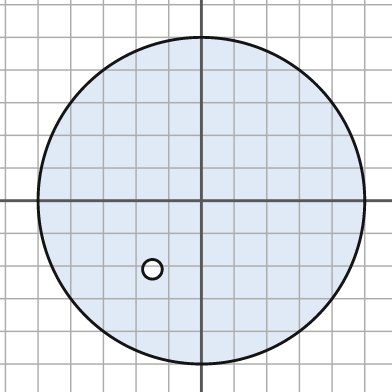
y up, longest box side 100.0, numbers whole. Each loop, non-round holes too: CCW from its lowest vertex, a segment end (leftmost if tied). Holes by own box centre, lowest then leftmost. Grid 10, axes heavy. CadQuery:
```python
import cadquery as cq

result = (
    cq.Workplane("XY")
    .moveTo(0.0, 0.0)
    .circle(50.0)
    .moveTo(-15.0, -21.0)
    .circle(3.0)
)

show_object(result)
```